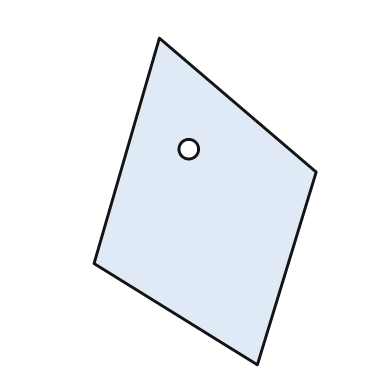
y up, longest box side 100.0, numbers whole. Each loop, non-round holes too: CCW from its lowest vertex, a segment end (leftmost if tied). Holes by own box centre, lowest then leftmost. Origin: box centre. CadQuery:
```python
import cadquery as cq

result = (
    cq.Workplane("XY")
    .moveTo(16.0, -50.0)
    .lineTo(34.0, 9.0)
    .lineTo(-14.0, 50.0)
    .lineTo(-34.0, -19.0)
    .close()
    .moveTo(-5.0, 16.0)
    .circle(3.0)
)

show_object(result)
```